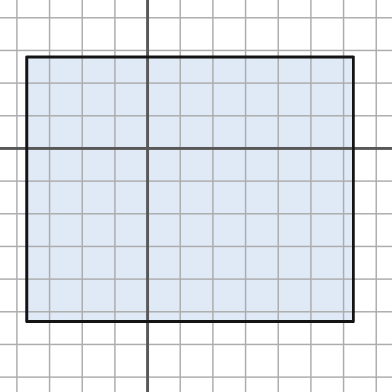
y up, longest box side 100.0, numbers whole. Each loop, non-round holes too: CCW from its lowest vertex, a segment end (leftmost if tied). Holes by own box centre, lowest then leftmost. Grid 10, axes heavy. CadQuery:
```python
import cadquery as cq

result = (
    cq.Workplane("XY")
    .moveTo(-37.0, -53.0)
    .lineTo(63.0, -53.0)
    .lineTo(63.0, 28.0)
    .lineTo(-37.0, 28.0)
    .close()
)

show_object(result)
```